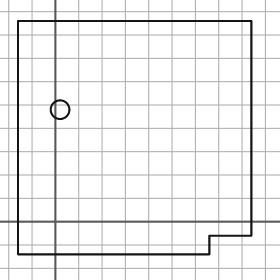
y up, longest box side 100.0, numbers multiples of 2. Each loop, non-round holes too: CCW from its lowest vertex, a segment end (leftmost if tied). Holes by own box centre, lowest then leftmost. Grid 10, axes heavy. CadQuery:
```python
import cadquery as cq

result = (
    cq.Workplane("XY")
    .moveTo(-16.0, -14.0)
    .lineTo(66.0, -14.0)
    .lineTo(66.0, -6.0)
    .lineTo(84.0, -6.0)
    .lineTo(84.0, 86.0)
    .lineTo(-16.0, 86.0)
    .close()
    .moveTo(2.0, 48.0)
    .circle(4.0)
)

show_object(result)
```